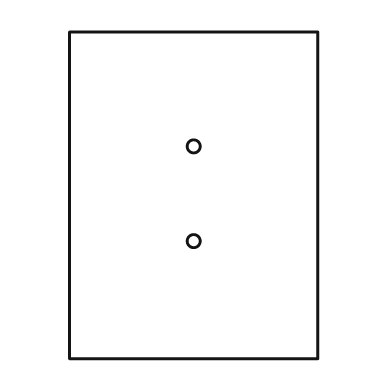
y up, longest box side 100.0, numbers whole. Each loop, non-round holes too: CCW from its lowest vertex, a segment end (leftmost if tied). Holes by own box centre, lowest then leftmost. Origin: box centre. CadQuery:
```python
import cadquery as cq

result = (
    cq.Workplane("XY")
    .moveTo(-38.0, -50.0)
    .lineTo(38.0, -50.0)
    .lineTo(38.0, 50.0)
    .lineTo(-38.0, 50.0)
    .close()
    .moveTo(0.0, -14.0)
    .circle(2.0)
    .moveTo(0.0, 15.0)
    .circle(2.0)
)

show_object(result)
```